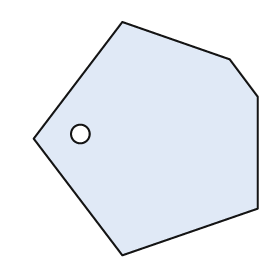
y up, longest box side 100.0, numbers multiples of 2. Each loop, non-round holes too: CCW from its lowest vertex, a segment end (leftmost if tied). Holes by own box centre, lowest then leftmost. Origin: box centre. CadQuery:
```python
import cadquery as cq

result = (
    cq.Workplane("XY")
    .moveTo(-10.0, -50.0)
    .lineTo(48.0, -30.0)
    .lineTo(48.0, 18.0)
    .lineTo(36.0, 34.0)
    .lineTo(-10.0, 50.0)
    .lineTo(-48.0, 0.0)
    .close()
    .moveTo(-28.0, 2.0)
    .circle(4.0)
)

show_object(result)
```